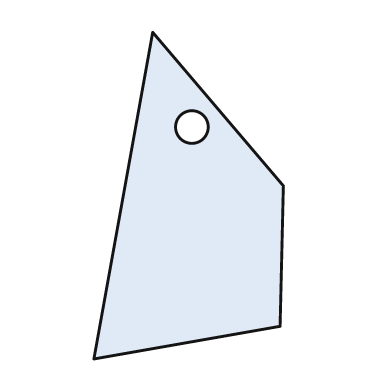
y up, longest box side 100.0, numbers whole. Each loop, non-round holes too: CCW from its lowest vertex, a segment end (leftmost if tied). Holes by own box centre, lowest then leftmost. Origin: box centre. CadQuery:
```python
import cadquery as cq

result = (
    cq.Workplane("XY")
    .moveTo(-29.0, -50.0)
    .lineTo(28.0, -40.0)
    .lineTo(29.0, 3.0)
    .lineTo(-11.0, 50.0)
    .close()
    .moveTo(1.0, 21.0)
    .circle(5.0)
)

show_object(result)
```